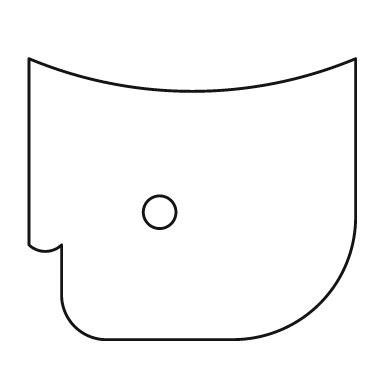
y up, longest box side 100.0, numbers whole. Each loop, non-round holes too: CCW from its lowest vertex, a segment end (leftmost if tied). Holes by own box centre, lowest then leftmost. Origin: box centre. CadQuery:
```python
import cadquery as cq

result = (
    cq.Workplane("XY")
    .moveTo(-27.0, -43.0)
    .lineTo(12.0, -43.0)
    .threePointArc((39.0, -32.0), (50.0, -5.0))
    .lineTo(50.0, 43.0)
    .threePointArc((0.0, 33.0), (-50.0, 43.0))
    .lineTo(-50.0, -14.0)
    .threePointArc((-45.0, -16.0), (-40.0, -14.0))
    .lineTo(-40.0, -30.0)
    .threePointArc((-36.0, -39.0), (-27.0, -43.0))
    .close()
    .moveTo(-10.0, -4.0)
    .circle(5.0)
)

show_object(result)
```